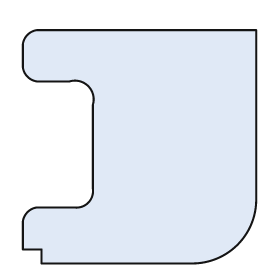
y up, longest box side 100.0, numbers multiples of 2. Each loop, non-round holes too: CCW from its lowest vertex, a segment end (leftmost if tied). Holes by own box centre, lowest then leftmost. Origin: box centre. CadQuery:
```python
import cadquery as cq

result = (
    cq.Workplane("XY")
    .moveTo(-42.0, -50.0)
    .lineTo(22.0, -50.0)
    .threePointArc((42.0, -42.0), (50.0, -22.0))
    .lineTo(50.0, 50.0)
    .lineTo(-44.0, 50.0)
    .threePointArc((-48.0, 48.0), (-50.0, 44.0))
    .lineTo(-50.0, 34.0)
    .threePointArc((-48.0, 30.0), (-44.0, 28.0))
    .lineTo(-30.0, 28.0)
    .threePointArc((-22.0, 26.0), (-20.0, 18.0))
    .lineTo(-20.0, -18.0)
    .threePointArc((-22.0, -24.0), (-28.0, -26.0))
    .lineTo(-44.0, -26.0)
    .threePointArc((-48.0, -28.0), (-50.0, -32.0))
    .lineTo(-50.0, -44.0)
    .lineTo(-42.0, -44.0)
    .close()
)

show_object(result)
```